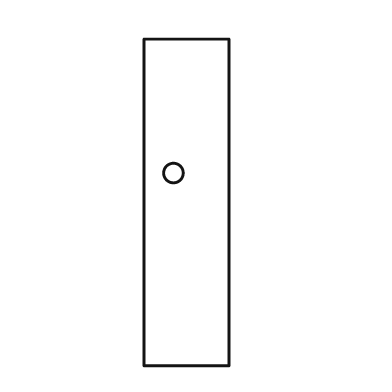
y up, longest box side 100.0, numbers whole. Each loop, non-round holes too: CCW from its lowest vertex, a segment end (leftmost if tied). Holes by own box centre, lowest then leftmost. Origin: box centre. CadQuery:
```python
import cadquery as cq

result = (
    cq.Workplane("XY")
    .moveTo(-13.0, -50.0)
    .lineTo(13.0, -50.0)
    .lineTo(13.0, 50.0)
    .lineTo(-13.0, 50.0)
    .close()
    .moveTo(-4.0, 9.0)
    .circle(3.0)
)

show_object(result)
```